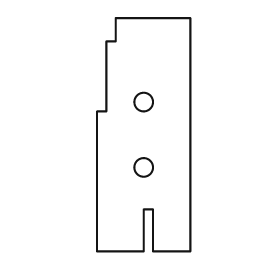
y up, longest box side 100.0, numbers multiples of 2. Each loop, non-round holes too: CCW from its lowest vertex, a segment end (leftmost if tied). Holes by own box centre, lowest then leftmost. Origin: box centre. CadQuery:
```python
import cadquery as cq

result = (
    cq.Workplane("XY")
    .moveTo(-20.0, -50.0)
    .lineTo(0.0, -50.0)
    .lineTo(0.0, -32.0)
    .lineTo(4.0, -32.0)
    .lineTo(4.0, -50.0)
    .lineTo(20.0, -50.0)
    .lineTo(20.0, 50.0)
    .lineTo(-12.0, 50.0)
    .lineTo(-12.0, 40.0)
    .lineTo(-16.0, 40.0)
    .lineTo(-16.0, 10.0)
    .lineTo(-20.0, 10.0)
    .close()
    .moveTo(0.0, -14.0)
    .circle(4.0)
    .moveTo(0.0, 14.0)
    .circle(4.0)
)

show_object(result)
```